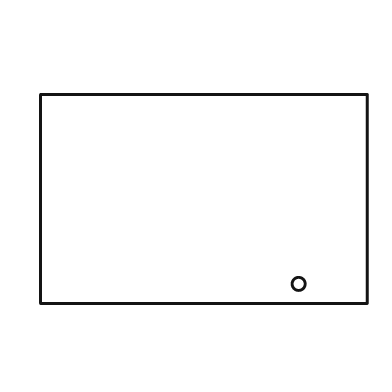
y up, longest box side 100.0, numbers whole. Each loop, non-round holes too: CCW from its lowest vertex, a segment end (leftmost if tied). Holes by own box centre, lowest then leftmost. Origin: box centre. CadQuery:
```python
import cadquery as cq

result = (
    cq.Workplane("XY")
    .moveTo(-50.0, -32.0)
    .lineTo(50.0, -32.0)
    .lineTo(50.0, 32.0)
    .lineTo(-50.0, 32.0)
    .close()
    .moveTo(29.0, -26.0)
    .circle(2.0)
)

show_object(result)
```